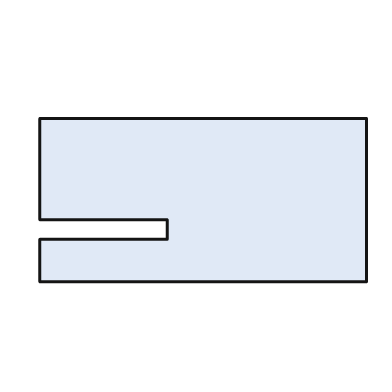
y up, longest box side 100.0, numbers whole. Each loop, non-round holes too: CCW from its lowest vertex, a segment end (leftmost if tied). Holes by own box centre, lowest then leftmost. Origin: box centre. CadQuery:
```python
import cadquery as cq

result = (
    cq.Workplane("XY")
    .moveTo(-50.0, -25.0)
    .lineTo(50.0, -25.0)
    .lineTo(50.0, 25.0)
    .lineTo(-50.0, 25.0)
    .lineTo(-50.0, -6.0)
    .lineTo(-11.0, -6.0)
    .lineTo(-11.0, -12.0)
    .lineTo(-50.0, -12.0)
    .close()
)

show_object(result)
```